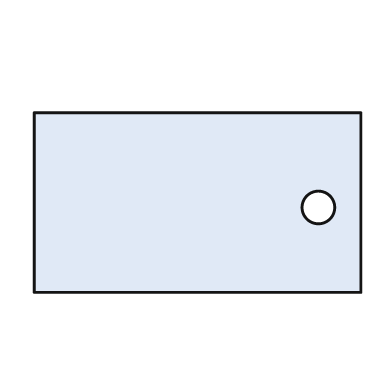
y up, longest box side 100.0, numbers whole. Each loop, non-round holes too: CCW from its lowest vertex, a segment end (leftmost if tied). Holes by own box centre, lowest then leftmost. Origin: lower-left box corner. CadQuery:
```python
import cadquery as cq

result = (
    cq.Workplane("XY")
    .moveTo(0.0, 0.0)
    .lineTo(100.0, 0.0)
    .lineTo(100.0, 55.0)
    .lineTo(0.0, 55.0)
    .close()
    .moveTo(87.0, 26.0)
    .circle(5.0)
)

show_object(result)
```